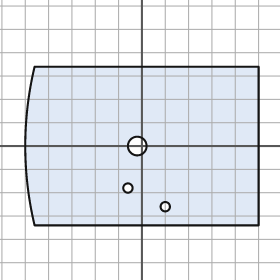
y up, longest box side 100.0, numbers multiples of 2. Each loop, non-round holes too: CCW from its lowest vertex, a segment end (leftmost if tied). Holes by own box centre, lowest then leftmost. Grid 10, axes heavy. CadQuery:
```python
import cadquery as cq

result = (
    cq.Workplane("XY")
    .moveTo(-46.0, -34.0)
    .lineTo(50.0, -34.0)
    .lineTo(50.0, 34.0)
    .lineTo(-46.0, 34.0)
    .threePointArc((-50.0, 0.0), (-46.0, -34.0))
    .close()
    .moveTo(10.0, -26.0)
    .circle(2.0)
    .moveTo(-6.0, -18.0)
    .circle(2.0)
    .moveTo(-2.0, 0.0)
    .circle(4.0)
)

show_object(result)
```